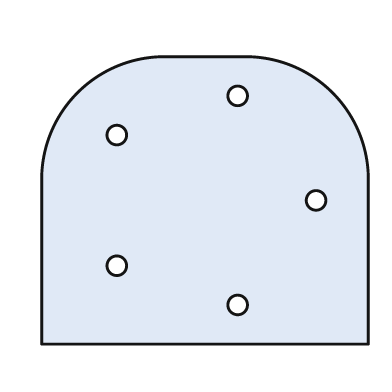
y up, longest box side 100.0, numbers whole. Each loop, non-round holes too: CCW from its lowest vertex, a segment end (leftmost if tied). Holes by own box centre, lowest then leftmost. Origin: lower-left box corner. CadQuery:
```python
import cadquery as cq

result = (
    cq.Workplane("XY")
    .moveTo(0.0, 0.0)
    .lineTo(100.0, 0.0)
    .lineTo(100.0, 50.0)
    .threePointArc((89.0, 77.0), (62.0, 88.0))
    .lineTo(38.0, 88.0)
    .threePointArc((11.0, 77.0), (0.0, 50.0))
    .close()
    .moveTo(60.0, 12.0)
    .circle(3.0)
    .moveTo(23.0, 24.0)
    .circle(3.0)
    .moveTo(84.0, 44.0)
    .circle(3.0)
    .moveTo(23.0, 64.0)
    .circle(3.0)
    .moveTo(60.0, 76.0)
    .circle(3.0)
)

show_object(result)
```